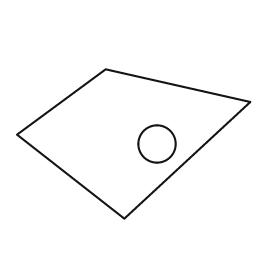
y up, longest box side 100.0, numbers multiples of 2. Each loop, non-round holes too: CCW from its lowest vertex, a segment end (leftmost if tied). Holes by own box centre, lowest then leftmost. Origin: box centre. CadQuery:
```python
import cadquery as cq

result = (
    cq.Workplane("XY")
    .moveTo(-4.0, -32.0)
    .lineTo(50.0, 18.0)
    .lineTo(-12.0, 32.0)
    .lineTo(-50.0, 4.0)
    .close()
    .moveTo(10.0, 0.0)
    .circle(8.0)
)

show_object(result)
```